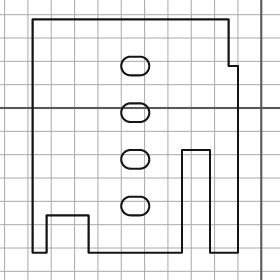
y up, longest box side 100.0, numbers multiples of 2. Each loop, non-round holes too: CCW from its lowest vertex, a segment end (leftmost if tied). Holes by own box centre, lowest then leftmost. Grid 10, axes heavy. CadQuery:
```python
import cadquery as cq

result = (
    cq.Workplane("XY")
    .moveTo(-98.0, -62.0)
    .lineTo(-92.0, -62.0)
    .lineTo(-92.0, -46.0)
    .lineTo(-74.0, -46.0)
    .lineTo(-74.0, -62.0)
    .lineTo(-34.0, -62.0)
    .lineTo(-34.0, -18.0)
    .lineTo(-22.0, -18.0)
    .lineTo(-22.0, -62.0)
    .lineTo(-10.0, -62.0)
    .lineTo(-10.0, 18.0)
    .lineTo(-14.0, 18.0)
    .lineTo(-14.0, 38.0)
    .lineTo(-98.0, 38.0)
    .close()
    .moveTo(-56.0, -46.0)
    .lineTo(-52.0, -46.0)
    .threePointArc((-48.0, -42.0), (-52.0, -38.0))
    .lineTo(-56.0, -38.0)
    .threePointArc((-60.0, -42.0), (-56.0, -46.0))
    .close()
    .moveTo(-56.0, -26.0)
    .lineTo(-52.0, -26.0)
    .threePointArc((-48.0, -22.0), (-52.0, -18.0))
    .lineTo(-56.0, -18.0)
    .threePointArc((-60.0, -22.0), (-56.0, -26.0))
    .close()
    .moveTo(-56.0, -6.0)
    .lineTo(-52.0, -6.0)
    .threePointArc((-48.0, -2.0), (-52.0, 2.0))
    .lineTo(-56.0, 2.0)
    .threePointArc((-60.0, -2.0), (-56.0, -6.0))
    .close()
    .moveTo(-56.0, 14.0)
    .lineTo(-52.0, 14.0)
    .threePointArc((-48.0, 18.0), (-52.0, 22.0))
    .lineTo(-56.0, 22.0)
    .threePointArc((-60.0, 18.0), (-56.0, 14.0))
    .close()
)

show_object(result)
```